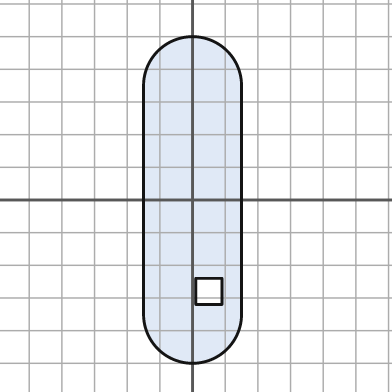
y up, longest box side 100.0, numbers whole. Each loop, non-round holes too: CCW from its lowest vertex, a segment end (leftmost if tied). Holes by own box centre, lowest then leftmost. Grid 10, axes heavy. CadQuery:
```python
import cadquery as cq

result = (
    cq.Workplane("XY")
    .moveTo(-15.0, -35.0)
    .threePointArc((0.0, -50.0), (15.0, -35.0))
    .lineTo(15.0, 35.0)
    .threePointArc((0.0, 50.0), (-15.0, 35.0))
    .close()
    .moveTo(1.0, -32.0)
    .lineTo(9.0, -32.0)
    .lineTo(9.0, -24.0)
    .lineTo(1.0, -24.0)
    .close()
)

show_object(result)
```